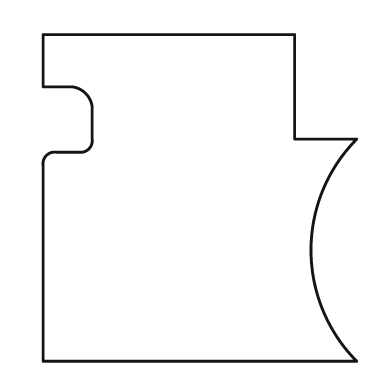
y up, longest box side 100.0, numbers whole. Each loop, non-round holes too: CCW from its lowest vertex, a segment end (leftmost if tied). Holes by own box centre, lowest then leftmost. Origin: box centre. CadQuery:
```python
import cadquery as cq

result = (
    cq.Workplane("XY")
    .moveTo(-48.0, -50.0)
    .lineTo(48.0, -50.0)
    .threePointArc((34.0, -16.0), (48.0, 18.0))
    .lineTo(29.0, 18.0)
    .lineTo(29.0, 50.0)
    .lineTo(-48.0, 50.0)
    .lineTo(-48.0, 34.0)
    .lineTo(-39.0, 34.0)
    .threePointArc((-35.0, 32.0), (-33.0, 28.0))
    .lineTo(-33.0, 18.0)
    .threePointArc((-34.0, 15.0), (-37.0, 14.0))
    .lineTo(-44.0, 14.0)
    .threePointArc((-47.0, 13.0), (-48.0, 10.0))
    .close()
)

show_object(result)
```